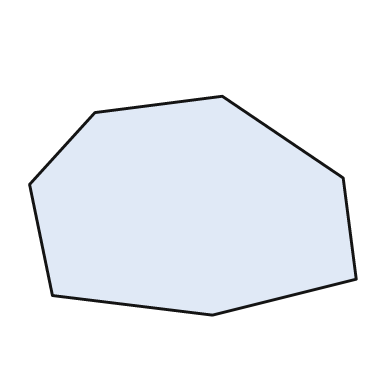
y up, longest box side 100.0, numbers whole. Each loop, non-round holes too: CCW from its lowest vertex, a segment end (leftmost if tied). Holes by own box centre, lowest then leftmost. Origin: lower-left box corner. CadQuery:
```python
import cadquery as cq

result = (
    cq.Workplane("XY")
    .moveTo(56.0, 0.0)
    .lineTo(100.0, 11.0)
    .lineTo(96.0, 42.0)
    .lineTo(59.0, 67.0)
    .lineTo(20.0, 62.0)
    .lineTo(0.0, 40.0)
    .lineTo(7.0, 6.0)
    .close()
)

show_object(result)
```